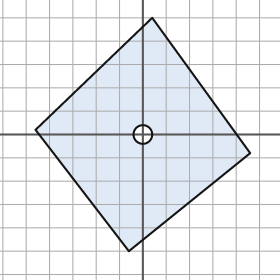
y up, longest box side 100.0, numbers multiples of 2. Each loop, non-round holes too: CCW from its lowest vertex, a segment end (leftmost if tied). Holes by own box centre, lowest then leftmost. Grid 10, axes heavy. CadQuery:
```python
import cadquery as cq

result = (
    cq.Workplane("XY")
    .moveTo(-6.0, -50.0)
    .lineTo(46.0, -8.0)
    .lineTo(4.0, 50.0)
    .lineTo(-46.0, 2.0)
    .close()
    .moveTo(0.0, 0.0)
    .circle(4.0)
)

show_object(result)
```